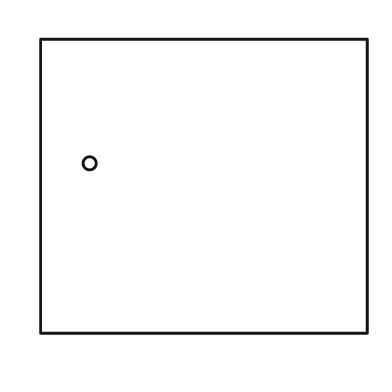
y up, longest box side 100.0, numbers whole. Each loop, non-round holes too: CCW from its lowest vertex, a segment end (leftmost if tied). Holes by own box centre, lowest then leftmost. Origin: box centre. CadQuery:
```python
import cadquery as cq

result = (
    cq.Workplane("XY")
    .moveTo(-50.0, -45.0)
    .lineTo(50.0, -45.0)
    .lineTo(50.0, 45.0)
    .lineTo(-50.0, 45.0)
    .close()
    .moveTo(-35.0, 7.0)
    .circle(2.0)
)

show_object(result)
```